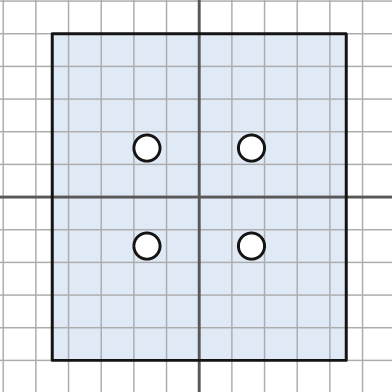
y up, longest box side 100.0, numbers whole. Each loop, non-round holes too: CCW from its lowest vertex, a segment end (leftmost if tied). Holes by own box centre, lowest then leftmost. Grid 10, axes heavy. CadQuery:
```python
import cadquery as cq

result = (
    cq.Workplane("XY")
    .moveTo(-45.0, -50.0)
    .lineTo(45.0, -50.0)
    .lineTo(45.0, 50.0)
    .lineTo(-45.0, 50.0)
    .close()
    .moveTo(-16.0, -15.0)
    .circle(4.0)
    .moveTo(16.0, -15.0)
    .circle(4.0)
    .moveTo(-16.0, 15.0)
    .circle(4.0)
    .moveTo(16.0, 15.0)
    .circle(4.0)
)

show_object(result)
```